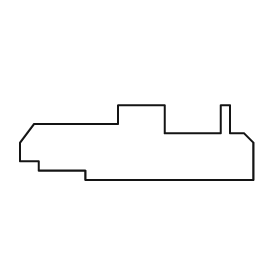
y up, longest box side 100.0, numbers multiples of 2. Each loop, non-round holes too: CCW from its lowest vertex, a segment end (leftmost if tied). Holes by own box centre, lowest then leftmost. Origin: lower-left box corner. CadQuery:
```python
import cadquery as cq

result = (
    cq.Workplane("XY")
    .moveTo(28.0, 0.0)
    .lineTo(100.0, 0.0)
    .lineTo(100.0, 16.0)
    .lineTo(96.0, 20.0)
    .lineTo(90.0, 20.0)
    .lineTo(90.0, 32.0)
    .lineTo(86.0, 32.0)
    .lineTo(86.0, 20.0)
    .lineTo(62.0, 20.0)
    .lineTo(62.0, 32.0)
    .lineTo(42.0, 32.0)
    .lineTo(42.0, 24.0)
    .lineTo(6.0, 24.0)
    .lineTo(0.0, 16.0)
    .lineTo(0.0, 8.0)
    .lineTo(8.0, 8.0)
    .lineTo(8.0, 4.0)
    .lineTo(28.0, 4.0)
    .close()
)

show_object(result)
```